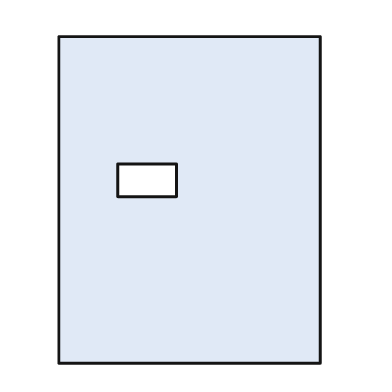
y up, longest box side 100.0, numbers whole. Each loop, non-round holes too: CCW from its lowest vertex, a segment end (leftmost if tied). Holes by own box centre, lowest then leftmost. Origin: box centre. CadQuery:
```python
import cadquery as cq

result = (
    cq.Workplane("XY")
    .moveTo(-40.0, -50.0)
    .lineTo(40.0, -50.0)
    .lineTo(40.0, 50.0)
    .lineTo(-40.0, 50.0)
    .close()
    .moveTo(-22.0, 1.0)
    .lineTo(-4.0, 1.0)
    .lineTo(-4.0, 11.0)
    .lineTo(-22.0, 11.0)
    .close()
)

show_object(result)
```